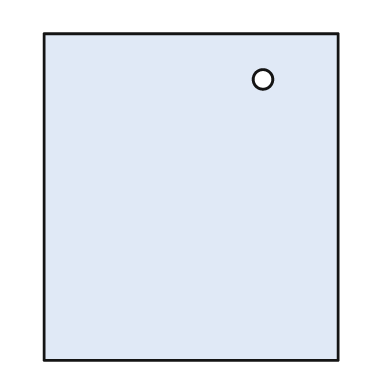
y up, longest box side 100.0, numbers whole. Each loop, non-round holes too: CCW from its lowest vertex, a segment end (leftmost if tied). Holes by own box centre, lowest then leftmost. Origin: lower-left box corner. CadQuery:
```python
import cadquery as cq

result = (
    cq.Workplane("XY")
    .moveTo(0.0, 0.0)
    .lineTo(90.0, 0.0)
    .lineTo(90.0, 100.0)
    .lineTo(0.0, 100.0)
    .close()
    .moveTo(67.0, 86.0)
    .circle(3.0)
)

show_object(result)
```